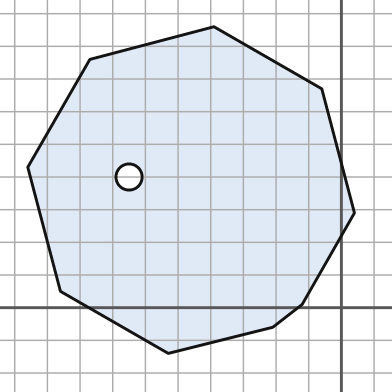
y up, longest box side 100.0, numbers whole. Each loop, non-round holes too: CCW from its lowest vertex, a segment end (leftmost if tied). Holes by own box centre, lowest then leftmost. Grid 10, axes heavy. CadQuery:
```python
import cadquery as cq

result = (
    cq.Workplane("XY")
    .moveTo(-53.0, -14.0)
    .lineTo(-21.0, -6.0)
    .lineTo(-12.0, 1.0)
    .lineTo(4.0, 29.0)
    .lineTo(-6.0, 67.0)
    .lineTo(-39.0, 86.0)
    .lineTo(-77.0, 76.0)
    .lineTo(-96.0, 43.0)
    .lineTo(-86.0, 5.0)
    .close()
    .moveTo(-65.0, 40.0)
    .circle(4.0)
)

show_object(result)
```